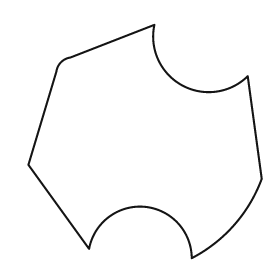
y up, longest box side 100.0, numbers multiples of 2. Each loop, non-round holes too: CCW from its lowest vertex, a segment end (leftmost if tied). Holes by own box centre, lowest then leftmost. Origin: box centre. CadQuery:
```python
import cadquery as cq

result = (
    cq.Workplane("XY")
    .moveTo(20.0, -50.0)
    .threePointArc((38.0, -36.0), (50.0, -16.0))
    .lineTo(44.0, 28.0)
    .threePointArc((16.0, 24.0), (4.0, 50.0))
    .lineTo(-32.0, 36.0)
    .threePointArc((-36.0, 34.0), (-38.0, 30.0))
    .lineTo(-50.0, -10.0)
    .lineTo(-24.0, -46.0)
    .threePointArc((0.0, -28.0), (20.0, -50.0))
    .close()
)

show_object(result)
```